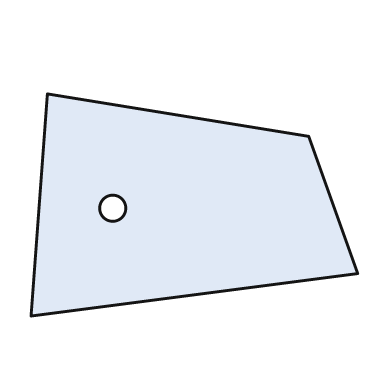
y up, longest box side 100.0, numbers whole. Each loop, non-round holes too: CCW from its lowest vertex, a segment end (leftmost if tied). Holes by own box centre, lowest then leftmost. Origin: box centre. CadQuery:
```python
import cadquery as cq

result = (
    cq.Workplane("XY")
    .moveTo(-50.0, -34.0)
    .lineTo(50.0, -21.0)
    .lineTo(35.0, 21.0)
    .lineTo(-45.0, 34.0)
    .close()
    .moveTo(-25.0, -1.0)
    .circle(4.0)
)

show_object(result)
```